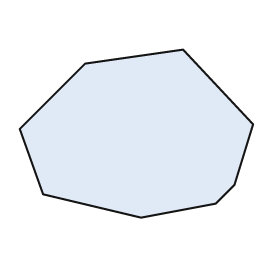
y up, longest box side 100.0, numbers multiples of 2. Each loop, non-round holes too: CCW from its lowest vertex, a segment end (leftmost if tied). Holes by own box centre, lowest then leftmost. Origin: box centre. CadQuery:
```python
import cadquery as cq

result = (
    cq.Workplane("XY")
    .moveTo(2.0, -36.0)
    .lineTo(34.0, -30.0)
    .lineTo(42.0, -22.0)
    .lineTo(50.0, 4.0)
    .lineTo(20.0, 36.0)
    .lineTo(-22.0, 30.0)
    .lineTo(-50.0, 2.0)
    .lineTo(-40.0, -26.0)
    .close()
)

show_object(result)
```